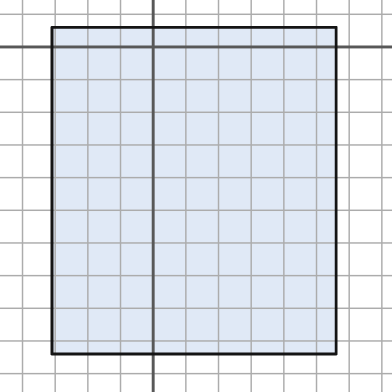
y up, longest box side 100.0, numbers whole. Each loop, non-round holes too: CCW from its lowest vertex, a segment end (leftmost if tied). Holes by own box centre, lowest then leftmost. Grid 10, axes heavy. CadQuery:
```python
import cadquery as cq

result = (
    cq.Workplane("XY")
    .moveTo(-31.0, -94.0)
    .lineTo(56.0, -94.0)
    .lineTo(56.0, 6.0)
    .lineTo(-31.0, 6.0)
    .close()
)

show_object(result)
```